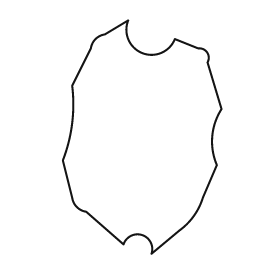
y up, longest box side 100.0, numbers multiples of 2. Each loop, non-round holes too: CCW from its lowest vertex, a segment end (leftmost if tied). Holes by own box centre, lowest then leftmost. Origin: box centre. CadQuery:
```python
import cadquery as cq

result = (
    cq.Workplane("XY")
    .moveTo(4.0, -50.0)
    .lineTo(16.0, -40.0)
    .threePointArc((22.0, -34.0), (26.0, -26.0))
    .lineTo(32.0, -12.0)
    .threePointArc((30.0, 0.0), (34.0, 12.0))
    .lineTo(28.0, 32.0)
    .threePointArc((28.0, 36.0), (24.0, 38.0))
    .lineTo(14.0, 42.0)
    .threePointArc((0.0, 36.0), (-6.0, 50.0))
    .lineTo(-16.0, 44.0)
    .threePointArc((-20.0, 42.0), (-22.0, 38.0))
    .lineTo(-30.0, 22.0)
    .threePointArc((-30.0, 6.0), (-34.0, -10.0))
    .lineTo(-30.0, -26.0)
    .threePointArc((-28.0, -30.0), (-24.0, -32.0))
    .lineTo(-8.0, -46.0)
    .threePointArc((0.0, -42.0), (4.0, -50.0))
    .close()
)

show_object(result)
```